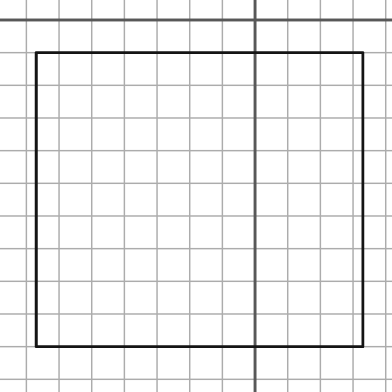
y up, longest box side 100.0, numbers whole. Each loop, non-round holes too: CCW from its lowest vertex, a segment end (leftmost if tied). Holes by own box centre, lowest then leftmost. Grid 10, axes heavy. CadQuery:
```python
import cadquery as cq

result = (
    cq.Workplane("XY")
    .moveTo(-67.0, -100.0)
    .lineTo(33.0, -100.0)
    .lineTo(33.0, -10.0)
    .lineTo(-67.0, -10.0)
    .close()
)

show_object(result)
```